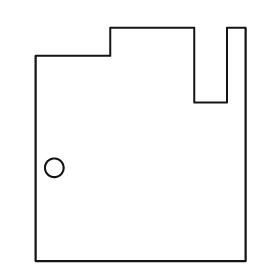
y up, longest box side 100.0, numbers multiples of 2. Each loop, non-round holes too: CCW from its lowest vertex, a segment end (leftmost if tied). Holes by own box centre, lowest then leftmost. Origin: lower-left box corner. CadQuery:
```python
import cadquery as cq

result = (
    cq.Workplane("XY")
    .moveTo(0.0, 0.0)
    .lineTo(90.0, 0.0)
    .lineTo(90.0, 100.0)
    .lineTo(82.0, 100.0)
    .lineTo(82.0, 68.0)
    .lineTo(68.0, 68.0)
    .lineTo(68.0, 100.0)
    .lineTo(32.0, 100.0)
    .lineTo(32.0, 88.0)
    .lineTo(0.0, 88.0)
    .close()
    .moveTo(8.0, 40.0)
    .circle(4.0)
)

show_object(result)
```